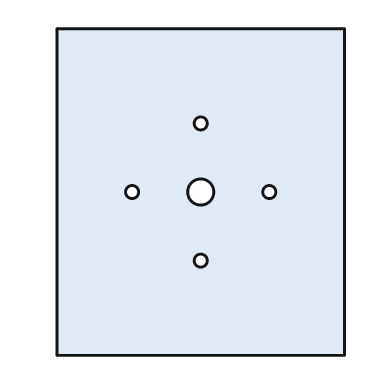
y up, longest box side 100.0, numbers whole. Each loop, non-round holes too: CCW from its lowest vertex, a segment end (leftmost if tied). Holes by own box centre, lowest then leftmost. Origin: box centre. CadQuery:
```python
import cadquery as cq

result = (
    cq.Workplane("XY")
    .moveTo(-44.0, -50.0)
    .lineTo(44.0, -50.0)
    .lineTo(44.0, 50.0)
    .lineTo(-44.0, 50.0)
    .close()
    .moveTo(0.0, -21.0)
    .circle(2.0)
    .moveTo(-21.0, 0.0)
    .circle(2.0)
    .moveTo(0.0, 0.0)
    .circle(4.0)
    .moveTo(21.0, 0.0)
    .circle(2.0)
    .moveTo(0.0, 21.0)
    .circle(2.0)
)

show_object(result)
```